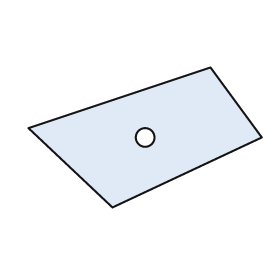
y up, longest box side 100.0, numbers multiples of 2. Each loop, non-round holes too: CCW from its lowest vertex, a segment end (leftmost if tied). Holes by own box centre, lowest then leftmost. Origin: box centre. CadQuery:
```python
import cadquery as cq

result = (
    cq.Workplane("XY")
    .moveTo(-14.0, -30.0)
    .lineTo(50.0, 0.0)
    .lineTo(28.0, 30.0)
    .lineTo(-50.0, 4.0)
    .close()
    .moveTo(0.0, 0.0)
    .circle(4.0)
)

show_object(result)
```